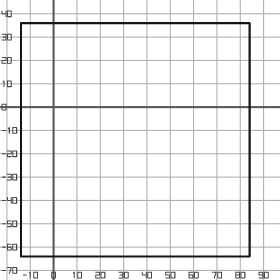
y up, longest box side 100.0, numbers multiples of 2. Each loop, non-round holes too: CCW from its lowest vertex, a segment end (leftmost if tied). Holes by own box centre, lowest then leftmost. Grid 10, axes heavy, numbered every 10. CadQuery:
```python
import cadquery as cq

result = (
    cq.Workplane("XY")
    .moveTo(-14.0, -64.0)
    .lineTo(84.0, -64.0)
    .lineTo(84.0, 36.0)
    .lineTo(-14.0, 36.0)
    .close()
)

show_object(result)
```